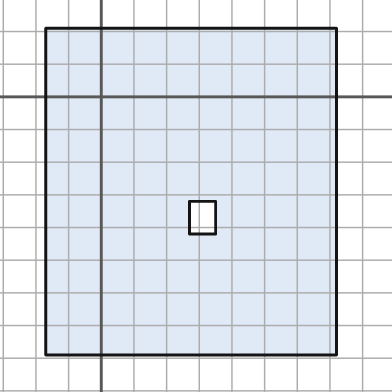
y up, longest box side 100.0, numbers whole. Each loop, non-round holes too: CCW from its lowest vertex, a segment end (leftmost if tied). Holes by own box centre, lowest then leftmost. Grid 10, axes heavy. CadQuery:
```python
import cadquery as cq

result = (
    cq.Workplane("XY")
    .moveTo(-17.0, -79.0)
    .lineTo(72.0, -79.0)
    .lineTo(72.0, 21.0)
    .lineTo(-17.0, 21.0)
    .close()
    .moveTo(27.0, -42.0)
    .lineTo(35.0, -42.0)
    .lineTo(35.0, -32.0)
    .lineTo(27.0, -32.0)
    .close()
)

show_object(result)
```